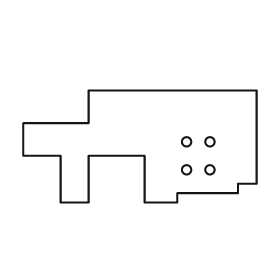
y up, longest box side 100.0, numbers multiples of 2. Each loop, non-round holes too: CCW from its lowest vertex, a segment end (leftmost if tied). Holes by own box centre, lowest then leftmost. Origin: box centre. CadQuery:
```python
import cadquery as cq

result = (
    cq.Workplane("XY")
    .moveTo(-34.0, -24.0)
    .lineTo(-22.0, -24.0)
    .lineTo(-22.0, -4.0)
    .lineTo(2.0, -4.0)
    .lineTo(2.0, -24.0)
    .lineTo(16.0, -24.0)
    .lineTo(16.0, -20.0)
    .lineTo(42.0, -20.0)
    .lineTo(42.0, -16.0)
    .lineTo(50.0, -16.0)
    .lineTo(50.0, 24.0)
    .lineTo(-22.0, 24.0)
    .lineTo(-22.0, 10.0)
    .lineTo(-50.0, 10.0)
    .lineTo(-50.0, -4.0)
    .lineTo(-34.0, -4.0)
    .close()
    .moveTo(20.0, -10.0)
    .circle(2.0)
    .moveTo(30.0, -10.0)
    .circle(2.0)
    .moveTo(20.0, 2.0)
    .circle(2.0)
    .moveTo(30.0, 2.0)
    .circle(2.0)
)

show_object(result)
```